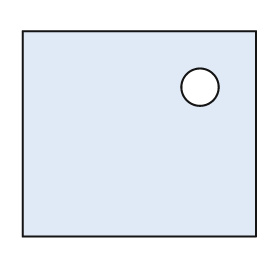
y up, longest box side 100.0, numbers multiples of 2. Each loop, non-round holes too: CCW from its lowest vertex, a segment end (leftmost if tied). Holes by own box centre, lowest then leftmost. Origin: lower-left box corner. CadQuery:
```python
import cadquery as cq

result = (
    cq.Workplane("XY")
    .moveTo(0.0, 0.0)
    .lineTo(100.0, 0.0)
    .lineTo(100.0, 88.0)
    .lineTo(0.0, 88.0)
    .close()
    .moveTo(76.0, 64.0)
    .circle(8.0)
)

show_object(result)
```